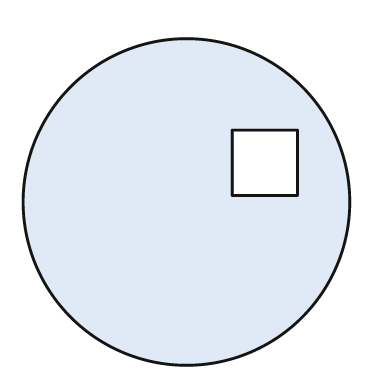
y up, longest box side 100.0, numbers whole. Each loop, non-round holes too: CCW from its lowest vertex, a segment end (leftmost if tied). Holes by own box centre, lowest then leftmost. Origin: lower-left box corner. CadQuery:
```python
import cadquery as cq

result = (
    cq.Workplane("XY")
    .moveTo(50.0, 50.0)
    .circle(50.0)
    .moveTo(64.0, 52.0)
    .lineTo(84.0, 52.0)
    .lineTo(84.0, 72.0)
    .lineTo(64.0, 72.0)
    .close()
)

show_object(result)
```